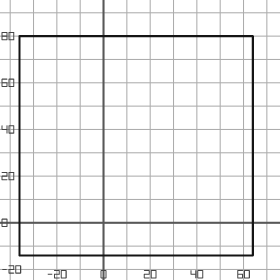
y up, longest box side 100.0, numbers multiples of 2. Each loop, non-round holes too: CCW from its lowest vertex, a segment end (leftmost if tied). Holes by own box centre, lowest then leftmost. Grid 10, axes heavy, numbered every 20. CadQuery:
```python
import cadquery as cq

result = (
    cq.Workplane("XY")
    .moveTo(-36.0, -14.0)
    .lineTo(64.0, -14.0)
    .lineTo(64.0, 80.0)
    .lineTo(-36.0, 80.0)
    .close()
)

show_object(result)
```